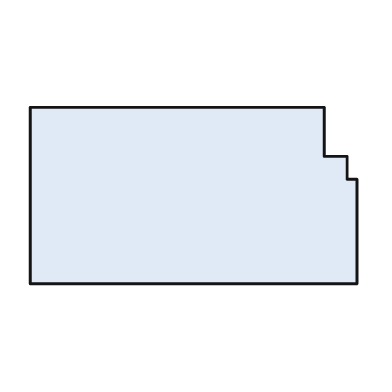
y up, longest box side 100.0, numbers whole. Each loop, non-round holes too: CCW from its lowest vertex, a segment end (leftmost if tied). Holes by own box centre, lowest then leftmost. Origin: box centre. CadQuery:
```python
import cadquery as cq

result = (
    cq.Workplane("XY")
    .moveTo(-50.0, -27.0)
    .lineTo(50.0, -27.0)
    .lineTo(50.0, 5.0)
    .lineTo(47.0, 5.0)
    .lineTo(47.0, 12.0)
    .lineTo(40.0, 12.0)
    .lineTo(40.0, 27.0)
    .lineTo(-50.0, 27.0)
    .close()
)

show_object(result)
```